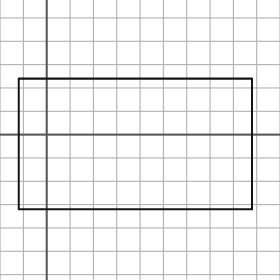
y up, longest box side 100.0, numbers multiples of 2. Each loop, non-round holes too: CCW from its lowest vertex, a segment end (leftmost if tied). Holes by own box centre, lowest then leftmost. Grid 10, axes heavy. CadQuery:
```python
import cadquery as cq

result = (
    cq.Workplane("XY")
    .moveTo(-12.0, -32.0)
    .lineTo(88.0, -32.0)
    .lineTo(88.0, 24.0)
    .lineTo(-12.0, 24.0)
    .close()
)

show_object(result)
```